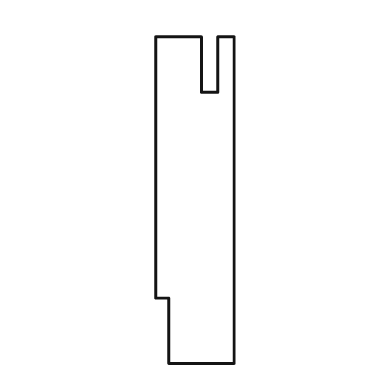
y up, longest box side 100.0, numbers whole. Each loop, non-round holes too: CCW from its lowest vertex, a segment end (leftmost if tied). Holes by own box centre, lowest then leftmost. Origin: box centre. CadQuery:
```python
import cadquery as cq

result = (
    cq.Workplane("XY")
    .moveTo(-8.0, -50.0)
    .lineTo(12.0, -50.0)
    .lineTo(12.0, 50.0)
    .lineTo(7.0, 50.0)
    .lineTo(7.0, 33.0)
    .lineTo(2.0, 33.0)
    .lineTo(2.0, 50.0)
    .lineTo(-12.0, 50.0)
    .lineTo(-12.0, -30.0)
    .lineTo(-8.0, -30.0)
    .close()
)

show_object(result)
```